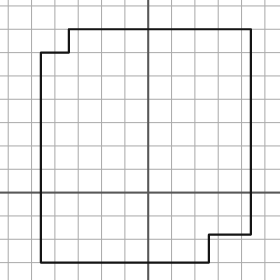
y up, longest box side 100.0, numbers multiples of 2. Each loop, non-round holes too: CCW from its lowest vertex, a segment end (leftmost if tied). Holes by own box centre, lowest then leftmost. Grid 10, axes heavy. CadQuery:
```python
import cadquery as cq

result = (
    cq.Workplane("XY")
    .moveTo(-46.0, -30.0)
    .lineTo(26.0, -30.0)
    .lineTo(26.0, -18.0)
    .lineTo(44.0, -18.0)
    .lineTo(44.0, 70.0)
    .lineTo(-34.0, 70.0)
    .lineTo(-34.0, 60.0)
    .lineTo(-46.0, 60.0)
    .close()
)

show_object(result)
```